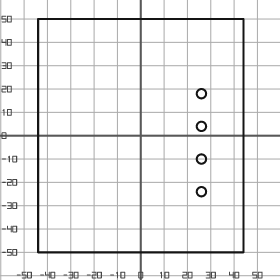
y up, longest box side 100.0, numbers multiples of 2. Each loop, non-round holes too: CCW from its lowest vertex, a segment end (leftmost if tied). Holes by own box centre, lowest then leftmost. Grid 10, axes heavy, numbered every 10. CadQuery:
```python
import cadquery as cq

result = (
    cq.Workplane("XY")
    .moveTo(-44.0, -50.0)
    .lineTo(44.0, -50.0)
    .lineTo(44.0, 50.0)
    .lineTo(-44.0, 50.0)
    .close()
    .moveTo(26.0, -24.0)
    .circle(2.0)
    .moveTo(26.0, -10.0)
    .circle(2.0)
    .moveTo(26.0, 4.0)
    .circle(2.0)
    .moveTo(26.0, 18.0)
    .circle(2.0)
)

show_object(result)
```